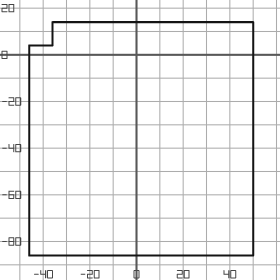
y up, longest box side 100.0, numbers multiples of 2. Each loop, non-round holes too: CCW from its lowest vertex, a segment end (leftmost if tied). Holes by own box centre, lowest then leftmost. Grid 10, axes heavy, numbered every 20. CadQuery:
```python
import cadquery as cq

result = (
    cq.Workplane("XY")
    .moveTo(-46.0, -86.0)
    .lineTo(50.0, -86.0)
    .lineTo(50.0, 14.0)
    .lineTo(-36.0, 14.0)
    .lineTo(-36.0, 4.0)
    .lineTo(-46.0, 4.0)
    .close()
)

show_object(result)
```